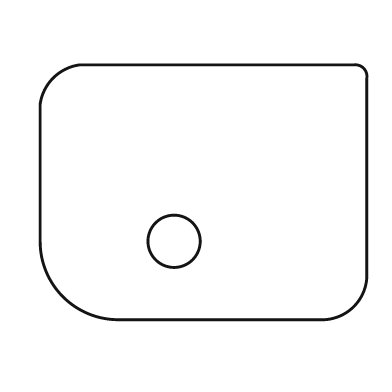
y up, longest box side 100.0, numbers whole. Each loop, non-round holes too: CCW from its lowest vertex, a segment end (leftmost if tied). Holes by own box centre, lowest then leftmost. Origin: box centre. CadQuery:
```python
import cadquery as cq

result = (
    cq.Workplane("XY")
    .moveTo(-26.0, -39.0)
    .lineTo(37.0, -39.0)
    .threePointArc((46.0, -35.0), (50.0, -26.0))
    .lineTo(50.0, 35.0)
    .threePointArc((49.0, 38.0), (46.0, 39.0))
    .lineTo(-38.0, 39.0)
    .threePointArc((-46.0, 35.0), (-50.0, 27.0))
    .lineTo(-50.0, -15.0)
    .threePointArc((-43.0, -32.0), (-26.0, -39.0))
    .close()
    .moveTo(-9.0, -15.0)
    .circle(8.0)
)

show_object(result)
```